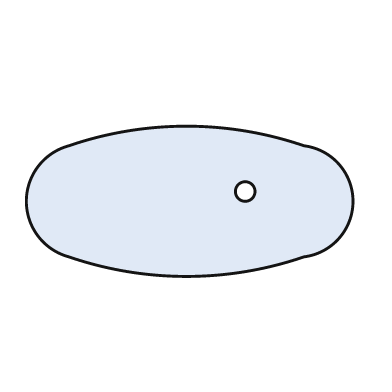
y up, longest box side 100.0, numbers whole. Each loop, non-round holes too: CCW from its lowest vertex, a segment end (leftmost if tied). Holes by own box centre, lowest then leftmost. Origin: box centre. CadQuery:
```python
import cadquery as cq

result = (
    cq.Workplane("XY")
    .moveTo(-37.0, -17.0)
    .threePointArc((-1.0, -23.0), (35.0, -17.0))
    .threePointArc((50.0, 0.0), (35.0, 17.0))
    .threePointArc((-1.0, 23.0), (-37.0, 17.0))
    .threePointArc((-50.0, 0.0), (-37.0, -17.0))
    .close()
    .moveTo(17.0, 3.0)
    .circle(3.0)
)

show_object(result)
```